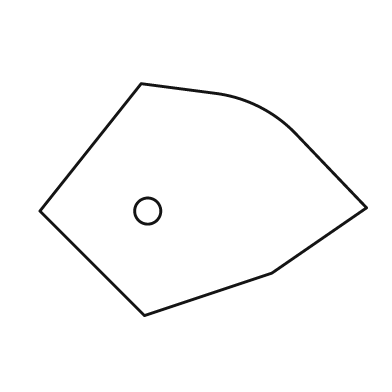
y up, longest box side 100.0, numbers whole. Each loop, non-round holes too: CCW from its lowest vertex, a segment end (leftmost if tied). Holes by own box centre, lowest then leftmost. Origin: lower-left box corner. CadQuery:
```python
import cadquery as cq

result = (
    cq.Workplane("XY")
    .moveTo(32.0, 0.0)
    .lineTo(71.0, 13.0)
    .lineTo(100.0, 33.0)
    .lineTo(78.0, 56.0)
    .threePointArc((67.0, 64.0), (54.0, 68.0))
    .lineTo(31.0, 71.0)
    .lineTo(0.0, 32.0)
    .close()
    .moveTo(33.0, 32.0)
    .circle(4.0)
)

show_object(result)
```